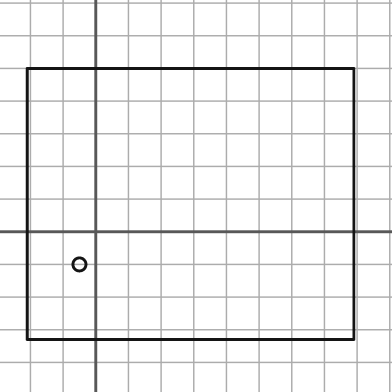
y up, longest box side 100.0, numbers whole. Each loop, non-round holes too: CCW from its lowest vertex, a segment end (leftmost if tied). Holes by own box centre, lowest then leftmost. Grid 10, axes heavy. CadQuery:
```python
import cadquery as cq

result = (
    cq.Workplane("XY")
    .moveTo(-21.0, -33.0)
    .lineTo(79.0, -33.0)
    .lineTo(79.0, 50.0)
    .lineTo(-21.0, 50.0)
    .close()
    .moveTo(-5.0, -10.0)
    .circle(2.0)
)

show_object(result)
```